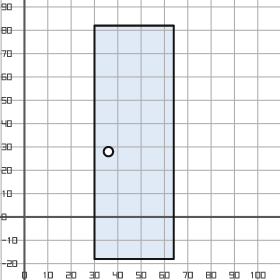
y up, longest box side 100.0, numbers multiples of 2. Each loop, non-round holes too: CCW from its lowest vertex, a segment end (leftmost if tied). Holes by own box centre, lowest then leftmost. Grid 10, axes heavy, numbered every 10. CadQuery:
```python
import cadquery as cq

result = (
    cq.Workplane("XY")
    .moveTo(30.0, -18.0)
    .lineTo(64.0, -18.0)
    .lineTo(64.0, 82.0)
    .lineTo(30.0, 82.0)
    .close()
    .moveTo(36.0, 28.0)
    .circle(2.0)
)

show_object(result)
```